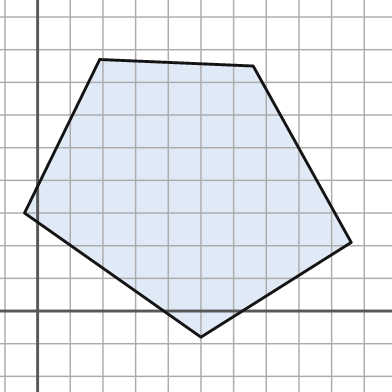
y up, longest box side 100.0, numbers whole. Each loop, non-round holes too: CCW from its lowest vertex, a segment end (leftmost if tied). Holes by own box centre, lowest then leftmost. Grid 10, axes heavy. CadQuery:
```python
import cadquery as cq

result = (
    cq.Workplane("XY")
    .moveTo(50.0, -8.0)
    .lineTo(96.0, 21.0)
    .lineTo(66.0, 75.0)
    .lineTo(19.0, 77.0)
    .lineTo(-4.0, 30.0)
    .close()
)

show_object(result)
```